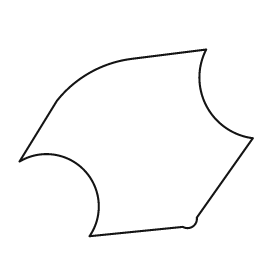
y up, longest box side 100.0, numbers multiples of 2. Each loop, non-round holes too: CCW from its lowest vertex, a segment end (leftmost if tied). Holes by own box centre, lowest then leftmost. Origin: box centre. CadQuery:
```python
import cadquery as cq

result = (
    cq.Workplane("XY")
    .moveTo(-20.0, -40.0)
    .lineTo(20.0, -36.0)
    .threePointArc((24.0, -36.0), (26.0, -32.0))
    .lineTo(50.0, 2.0)
    .threePointArc((30.0, 16.0), (30.0, 40.0))
    .lineTo(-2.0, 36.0)
    .threePointArc((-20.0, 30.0), (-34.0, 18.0))
    .lineTo(-50.0, -8.0)
    .threePointArc((-22.0, -12.0), (-20.0, -40.0))
    .close()
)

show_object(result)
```